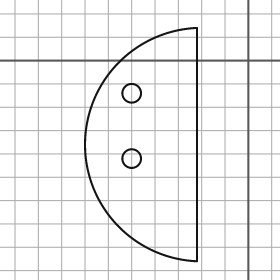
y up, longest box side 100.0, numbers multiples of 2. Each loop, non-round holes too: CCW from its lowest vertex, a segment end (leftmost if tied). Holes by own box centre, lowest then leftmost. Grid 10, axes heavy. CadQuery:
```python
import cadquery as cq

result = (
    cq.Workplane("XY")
    .moveTo(-22.0, -86.0)
    .lineTo(-22.0, 14.0)
    .threePointArc((-70.0, -36.0), (-22.0, -86.0))
    .close()
    .moveTo(-50.0, -42.0)
    .circle(4.0)
    .moveTo(-50.0, -14.0)
    .circle(4.0)
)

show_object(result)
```